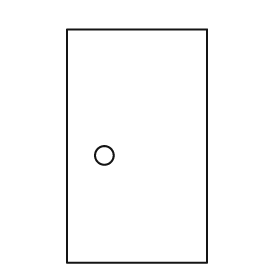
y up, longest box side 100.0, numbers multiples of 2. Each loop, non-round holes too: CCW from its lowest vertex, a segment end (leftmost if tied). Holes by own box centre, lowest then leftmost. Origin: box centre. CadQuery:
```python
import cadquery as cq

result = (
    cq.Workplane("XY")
    .moveTo(-30.0, -50.0)
    .lineTo(30.0, -50.0)
    .lineTo(30.0, 50.0)
    .lineTo(-30.0, 50.0)
    .close()
    .moveTo(-14.0, -4.0)
    .circle(4.0)
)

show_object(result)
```